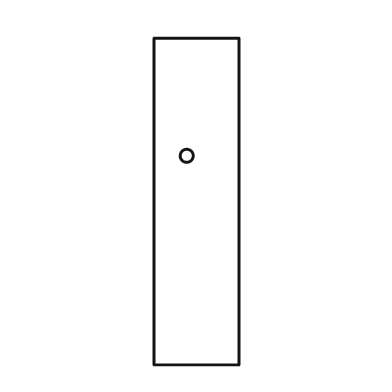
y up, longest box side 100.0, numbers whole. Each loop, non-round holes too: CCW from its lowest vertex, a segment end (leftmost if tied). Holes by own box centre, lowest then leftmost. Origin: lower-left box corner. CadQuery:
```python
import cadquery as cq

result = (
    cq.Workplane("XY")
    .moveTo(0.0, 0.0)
    .lineTo(26.0, 0.0)
    .lineTo(26.0, 100.0)
    .lineTo(0.0, 100.0)
    .close()
    .moveTo(10.0, 64.0)
    .circle(2.0)
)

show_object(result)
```